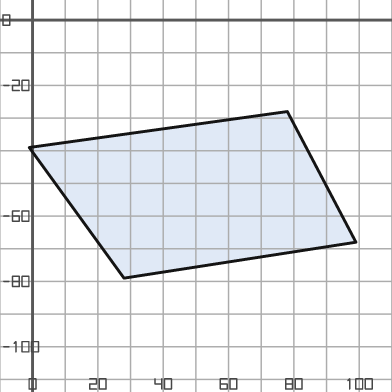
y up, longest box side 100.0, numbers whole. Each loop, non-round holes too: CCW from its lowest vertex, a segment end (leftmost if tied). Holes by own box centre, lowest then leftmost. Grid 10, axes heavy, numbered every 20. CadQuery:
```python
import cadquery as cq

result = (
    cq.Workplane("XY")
    .moveTo(28.0, -79.0)
    .lineTo(99.0, -68.0)
    .lineTo(78.0, -28.0)
    .lineTo(-1.0, -39.0)
    .close()
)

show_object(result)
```